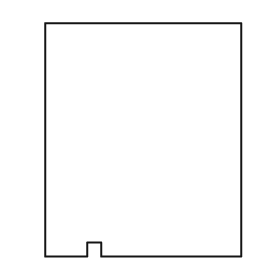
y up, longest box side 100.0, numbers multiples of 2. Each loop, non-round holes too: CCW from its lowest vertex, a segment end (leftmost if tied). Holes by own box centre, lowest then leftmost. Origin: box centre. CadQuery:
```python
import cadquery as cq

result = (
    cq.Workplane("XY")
    .moveTo(-42.0, -50.0)
    .lineTo(-24.0, -50.0)
    .lineTo(-24.0, -44.0)
    .lineTo(-18.0, -44.0)
    .lineTo(-18.0, -50.0)
    .lineTo(42.0, -50.0)
    .lineTo(42.0, 50.0)
    .lineTo(-42.0, 50.0)
    .close()
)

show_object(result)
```